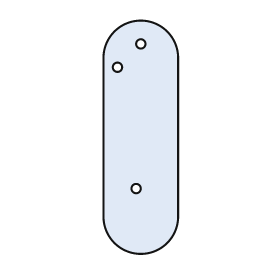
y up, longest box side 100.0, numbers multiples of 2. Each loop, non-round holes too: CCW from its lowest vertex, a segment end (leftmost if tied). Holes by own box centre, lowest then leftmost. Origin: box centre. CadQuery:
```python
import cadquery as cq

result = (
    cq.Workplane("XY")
    .moveTo(-16.0, -34.0)
    .threePointArc((0.0, -50.0), (16.0, -34.0))
    .lineTo(16.0, 34.0)
    .threePointArc((0.0, 50.0), (-16.0, 34.0))
    .close()
    .moveTo(-2.0, -22.0)
    .circle(2.0)
    .moveTo(-10.0, 30.0)
    .circle(2.0)
    .moveTo(0.0, 40.0)
    .circle(2.0)
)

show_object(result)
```